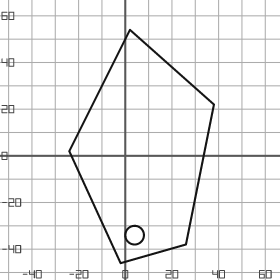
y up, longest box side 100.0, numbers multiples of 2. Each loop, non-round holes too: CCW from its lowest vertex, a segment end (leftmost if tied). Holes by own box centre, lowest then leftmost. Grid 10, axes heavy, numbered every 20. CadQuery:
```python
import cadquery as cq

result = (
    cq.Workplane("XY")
    .moveTo(-2.0, -46.0)
    .lineTo(26.0, -38.0)
    .lineTo(38.0, 22.0)
    .lineTo(2.0, 54.0)
    .lineTo(-24.0, 2.0)
    .close()
    .moveTo(4.0, -34.0)
    .circle(4.0)
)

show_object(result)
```